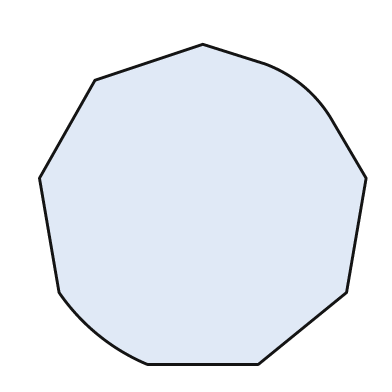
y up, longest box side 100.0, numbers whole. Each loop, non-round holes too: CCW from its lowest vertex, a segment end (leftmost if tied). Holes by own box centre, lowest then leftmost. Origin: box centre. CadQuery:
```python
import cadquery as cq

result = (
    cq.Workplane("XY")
    .moveTo(-17.0, -49.0)
    .lineTo(17.0, -49.0)
    .lineTo(44.0, -27.0)
    .lineTo(50.0, 8.0)
    .lineTo(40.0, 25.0)
    .threePointArc((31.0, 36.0), (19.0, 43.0))
    .lineTo(0.0, 49.0)
    .lineTo(-33.0, 38.0)
    .lineTo(-50.0, 8.0)
    .lineTo(-44.0, -27.0)
    .threePointArc((-32.0, -40.0), (-17.0, -49.0))
    .close()
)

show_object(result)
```